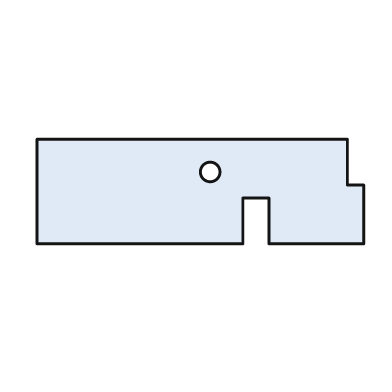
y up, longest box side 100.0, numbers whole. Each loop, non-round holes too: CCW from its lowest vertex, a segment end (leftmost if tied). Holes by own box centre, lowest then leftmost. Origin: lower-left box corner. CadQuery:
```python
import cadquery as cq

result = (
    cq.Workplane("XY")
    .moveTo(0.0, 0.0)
    .lineTo(63.0, 0.0)
    .lineTo(63.0, 14.0)
    .lineTo(71.0, 14.0)
    .lineTo(71.0, 0.0)
    .lineTo(100.0, 0.0)
    .lineTo(100.0, 18.0)
    .lineTo(95.0, 18.0)
    .lineTo(95.0, 32.0)
    .lineTo(0.0, 32.0)
    .close()
    .moveTo(53.0, 22.0)
    .circle(3.0)
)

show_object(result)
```